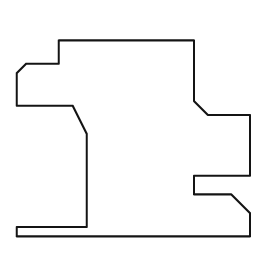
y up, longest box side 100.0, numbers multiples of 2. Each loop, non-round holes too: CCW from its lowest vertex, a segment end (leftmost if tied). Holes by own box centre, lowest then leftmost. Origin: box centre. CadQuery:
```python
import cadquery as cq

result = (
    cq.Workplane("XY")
    .moveTo(-50.0, -42.0)
    .lineTo(50.0, -42.0)
    .lineTo(50.0, -32.0)
    .lineTo(42.0, -24.0)
    .lineTo(26.0, -24.0)
    .lineTo(26.0, -16.0)
    .lineTo(50.0, -16.0)
    .lineTo(50.0, 10.0)
    .lineTo(32.0, 10.0)
    .lineTo(26.0, 16.0)
    .lineTo(26.0, 42.0)
    .lineTo(-32.0, 42.0)
    .lineTo(-32.0, 32.0)
    .lineTo(-46.0, 32.0)
    .lineTo(-50.0, 28.0)
    .lineTo(-50.0, 14.0)
    .lineTo(-26.0, 14.0)
    .lineTo(-20.0, 2.0)
    .lineTo(-20.0, -38.0)
    .lineTo(-50.0, -38.0)
    .close()
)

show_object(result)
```